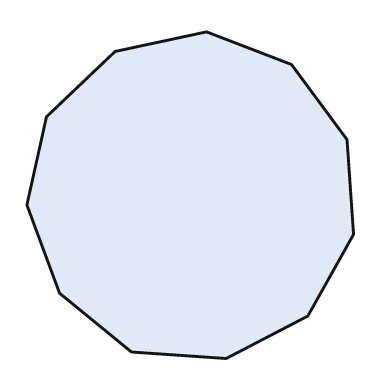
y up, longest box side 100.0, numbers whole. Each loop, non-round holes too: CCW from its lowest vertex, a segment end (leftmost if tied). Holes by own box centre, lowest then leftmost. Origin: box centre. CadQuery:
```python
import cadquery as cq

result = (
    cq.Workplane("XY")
    .moveTo(11.0, -50.0)
    .lineTo(36.0, -37.0)
    .lineTo(50.0, -12.0)
    .lineTo(48.0, 17.0)
    .lineTo(31.0, 40.0)
    .lineTo(5.0, 50.0)
    .lineTo(-23.0, 44.0)
    .lineTo(-44.0, 24.0)
    .lineTo(-50.0, -3.0)
    .lineTo(-40.0, -30.0)
    .lineTo(-18.0, -48.0)
    .close()
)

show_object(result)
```